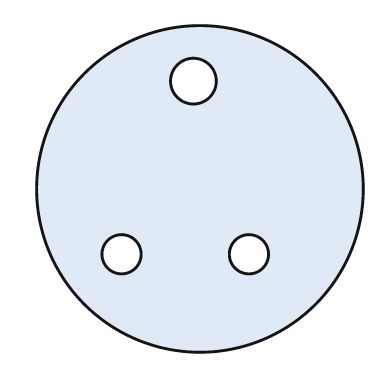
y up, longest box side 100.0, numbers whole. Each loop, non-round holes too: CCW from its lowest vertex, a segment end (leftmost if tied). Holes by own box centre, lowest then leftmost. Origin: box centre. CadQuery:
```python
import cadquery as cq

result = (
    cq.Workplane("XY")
    .moveTo(0.0, 0.0)
    .circle(50.0)
    .moveTo(-24.0, -20.0)
    .circle(6.0)
    .moveTo(15.0, -20.0)
    .circle(6.0)
    .moveTo(-2.0, 33.0)
    .circle(7.0)
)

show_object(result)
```